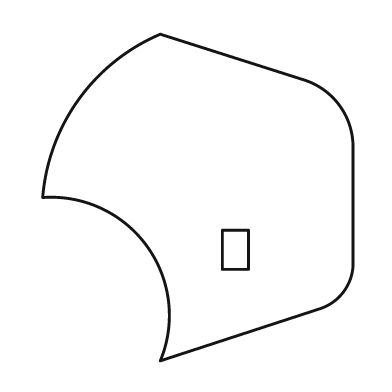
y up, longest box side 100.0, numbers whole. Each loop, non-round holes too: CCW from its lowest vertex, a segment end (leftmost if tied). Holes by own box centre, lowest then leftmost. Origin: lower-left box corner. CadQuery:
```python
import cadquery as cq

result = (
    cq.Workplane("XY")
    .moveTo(36.0, 0.0)
    .lineTo(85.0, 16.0)
    .threePointArc((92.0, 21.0), (95.0, 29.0))
    .lineTo(95.0, 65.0)
    .threePointArc((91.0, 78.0), (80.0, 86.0))
    .lineTo(36.0, 100.0)
    .threePointArc((11.0, 80.0), (0.0, 50.0))
    .threePointArc((32.0, 35.0), (36.0, 0.0))
    .close()
    .moveTo(55.0, 28.0)
    .lineTo(63.0, 28.0)
    .lineTo(63.0, 40.0)
    .lineTo(55.0, 40.0)
    .close()
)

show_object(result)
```